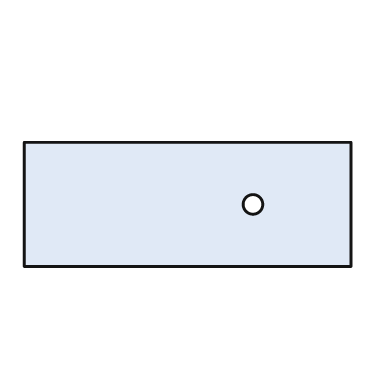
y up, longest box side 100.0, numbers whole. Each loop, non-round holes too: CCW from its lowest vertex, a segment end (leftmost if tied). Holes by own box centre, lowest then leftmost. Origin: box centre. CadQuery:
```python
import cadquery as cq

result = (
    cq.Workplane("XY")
    .moveTo(-50.0, -19.0)
    .lineTo(50.0, -19.0)
    .lineTo(50.0, 19.0)
    .lineTo(-50.0, 19.0)
    .close()
    .moveTo(20.0, 0.0)
    .circle(3.0)
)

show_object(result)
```